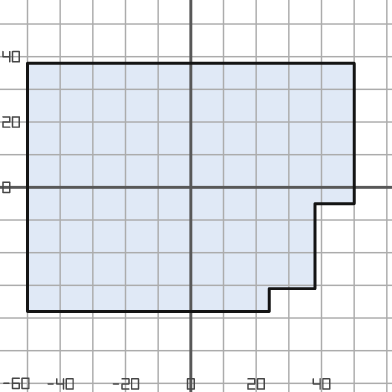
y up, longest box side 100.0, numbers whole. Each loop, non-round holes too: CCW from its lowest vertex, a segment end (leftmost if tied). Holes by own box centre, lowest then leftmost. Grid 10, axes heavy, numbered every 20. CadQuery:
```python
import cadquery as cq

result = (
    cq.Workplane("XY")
    .moveTo(-50.0, -38.0)
    .lineTo(24.0, -38.0)
    .lineTo(24.0, -31.0)
    .lineTo(38.0, -31.0)
    .lineTo(38.0, -5.0)
    .lineTo(50.0, -5.0)
    .lineTo(50.0, 38.0)
    .lineTo(-50.0, 38.0)
    .close()
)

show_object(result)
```